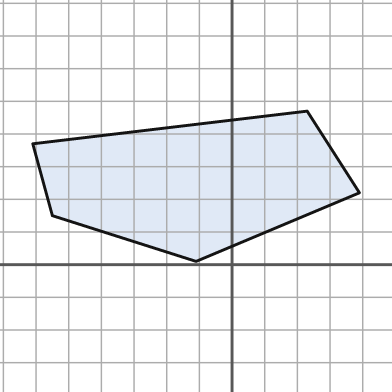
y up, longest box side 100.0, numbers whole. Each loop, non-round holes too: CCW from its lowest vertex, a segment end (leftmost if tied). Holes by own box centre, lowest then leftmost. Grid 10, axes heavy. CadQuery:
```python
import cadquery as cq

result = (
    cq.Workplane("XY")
    .moveTo(-11.0, 1.0)
    .lineTo(39.0, 22.0)
    .lineTo(23.0, 47.0)
    .lineTo(-61.0, 37.0)
    .lineTo(-55.0, 15.0)
    .close()
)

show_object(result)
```